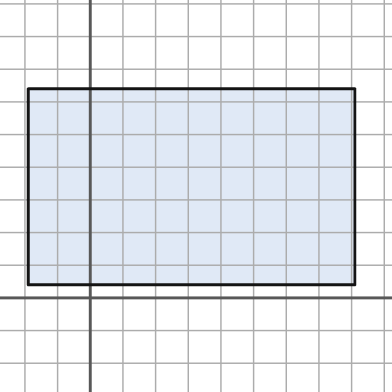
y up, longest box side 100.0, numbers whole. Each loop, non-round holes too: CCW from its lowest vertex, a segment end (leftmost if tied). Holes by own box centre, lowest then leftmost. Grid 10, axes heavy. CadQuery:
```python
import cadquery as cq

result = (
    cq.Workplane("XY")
    .moveTo(-19.0, 4.0)
    .lineTo(81.0, 4.0)
    .lineTo(81.0, 64.0)
    .lineTo(-19.0, 64.0)
    .close()
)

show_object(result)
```